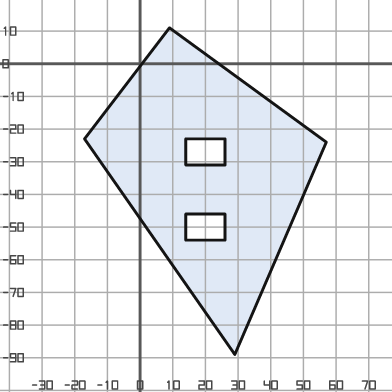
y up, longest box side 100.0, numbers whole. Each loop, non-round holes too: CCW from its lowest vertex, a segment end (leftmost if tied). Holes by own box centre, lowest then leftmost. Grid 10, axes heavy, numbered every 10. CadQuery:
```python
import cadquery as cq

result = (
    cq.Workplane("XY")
    .moveTo(29.0, -89.0)
    .lineTo(57.0, -24.0)
    .lineTo(9.0, 11.0)
    .lineTo(-17.0, -23.0)
    .close()
    .moveTo(14.0, -54.0)
    .lineTo(26.0, -54.0)
    .lineTo(26.0, -46.0)
    .lineTo(14.0, -46.0)
    .close()
    .moveTo(14.0, -31.0)
    .lineTo(26.0, -31.0)
    .lineTo(26.0, -23.0)
    .lineTo(14.0, -23.0)
    .close()
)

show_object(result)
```